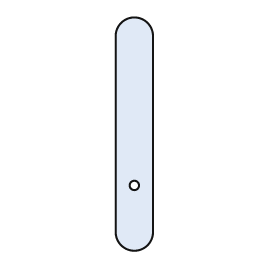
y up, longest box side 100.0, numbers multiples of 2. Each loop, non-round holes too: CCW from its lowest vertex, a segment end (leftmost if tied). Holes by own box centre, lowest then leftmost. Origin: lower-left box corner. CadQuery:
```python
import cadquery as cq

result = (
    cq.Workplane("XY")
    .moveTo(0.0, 8.0)
    .threePointArc((8.0, 0.0), (16.0, 8.0))
    .lineTo(16.0, 92.0)
    .threePointArc((8.0, 100.0), (0.0, 92.0))
    .close()
    .moveTo(8.0, 28.0)
    .circle(2.0)
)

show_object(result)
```